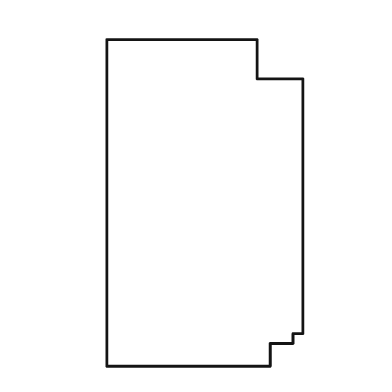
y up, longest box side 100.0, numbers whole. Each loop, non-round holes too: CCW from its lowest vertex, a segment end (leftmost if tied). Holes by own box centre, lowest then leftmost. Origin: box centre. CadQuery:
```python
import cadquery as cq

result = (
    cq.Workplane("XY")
    .moveTo(-30.0, -50.0)
    .lineTo(20.0, -50.0)
    .lineTo(20.0, -43.0)
    .lineTo(27.0, -43.0)
    .lineTo(27.0, -40.0)
    .lineTo(30.0, -40.0)
    .lineTo(30.0, 38.0)
    .lineTo(16.0, 38.0)
    .lineTo(16.0, 50.0)
    .lineTo(-30.0, 50.0)
    .close()
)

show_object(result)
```